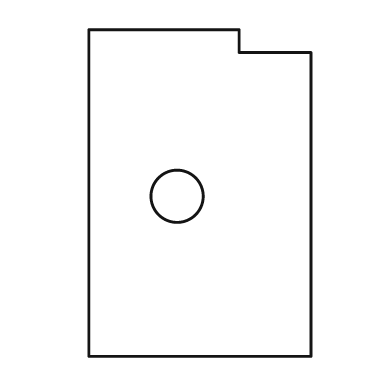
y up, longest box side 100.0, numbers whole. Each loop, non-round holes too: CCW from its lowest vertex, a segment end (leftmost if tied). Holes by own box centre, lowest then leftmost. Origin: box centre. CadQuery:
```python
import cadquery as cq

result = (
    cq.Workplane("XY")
    .moveTo(-34.0, -50.0)
    .lineTo(34.0, -50.0)
    .lineTo(34.0, 43.0)
    .lineTo(12.0, 43.0)
    .lineTo(12.0, 50.0)
    .lineTo(-34.0, 50.0)
    .close()
    .moveTo(-7.0, -1.0)
    .circle(8.0)
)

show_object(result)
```